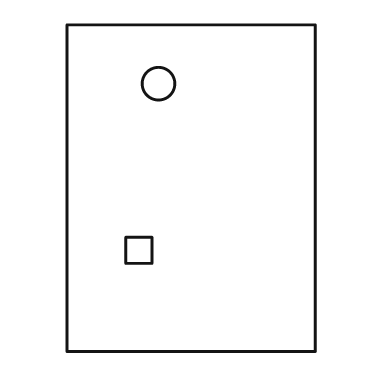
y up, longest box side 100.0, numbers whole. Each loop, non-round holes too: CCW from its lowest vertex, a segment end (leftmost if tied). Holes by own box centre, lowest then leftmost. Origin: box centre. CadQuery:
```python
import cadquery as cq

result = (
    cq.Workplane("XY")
    .moveTo(-38.0, -50.0)
    .lineTo(38.0, -50.0)
    .lineTo(38.0, 50.0)
    .lineTo(-38.0, 50.0)
    .close()
    .moveTo(-20.0, -23.0)
    .lineTo(-12.0, -23.0)
    .lineTo(-12.0, -15.0)
    .lineTo(-20.0, -15.0)
    .close()
    .moveTo(-10.0, 32.0)
    .circle(5.0)
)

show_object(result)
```